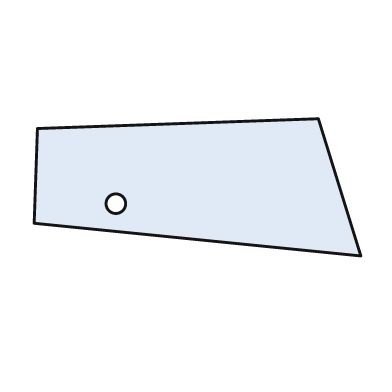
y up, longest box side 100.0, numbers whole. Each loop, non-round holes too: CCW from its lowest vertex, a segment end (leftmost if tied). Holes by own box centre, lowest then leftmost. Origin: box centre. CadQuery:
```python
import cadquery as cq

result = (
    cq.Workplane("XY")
    .moveTo(50.0, -21.0)
    .lineTo(37.0, 21.0)
    .lineTo(-49.0, 18.0)
    .lineTo(-50.0, -11.0)
    .close()
    .moveTo(-25.0, -5.0)
    .circle(3.0)
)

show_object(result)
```